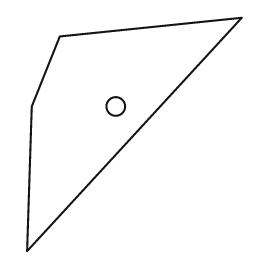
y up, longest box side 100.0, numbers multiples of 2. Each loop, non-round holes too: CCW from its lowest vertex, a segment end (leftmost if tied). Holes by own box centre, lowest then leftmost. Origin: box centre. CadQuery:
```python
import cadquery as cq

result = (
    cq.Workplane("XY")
    .moveTo(-46.0, -50.0)
    .lineTo(46.0, 50.0)
    .lineTo(-32.0, 42.0)
    .lineTo(-44.0, 12.0)
    .close()
    .moveTo(-8.0, 12.0)
    .circle(4.0)
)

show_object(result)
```